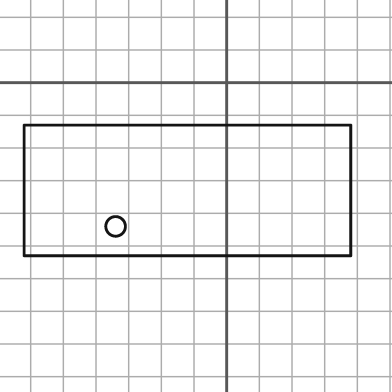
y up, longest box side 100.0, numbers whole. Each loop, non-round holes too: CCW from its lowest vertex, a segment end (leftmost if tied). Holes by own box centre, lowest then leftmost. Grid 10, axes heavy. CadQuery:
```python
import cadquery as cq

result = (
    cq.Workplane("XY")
    .moveTo(-62.0, -53.0)
    .lineTo(38.0, -53.0)
    .lineTo(38.0, -13.0)
    .lineTo(-62.0, -13.0)
    .close()
    .moveTo(-34.0, -44.0)
    .circle(3.0)
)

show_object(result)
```